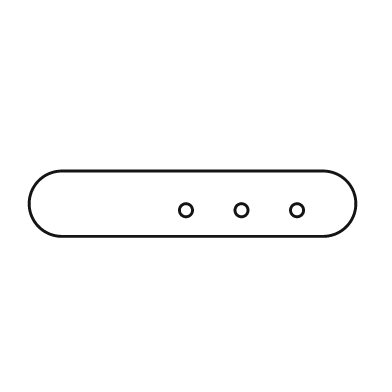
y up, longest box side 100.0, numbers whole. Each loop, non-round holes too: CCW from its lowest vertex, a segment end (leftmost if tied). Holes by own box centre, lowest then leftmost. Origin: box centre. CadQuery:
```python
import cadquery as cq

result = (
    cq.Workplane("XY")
    .moveTo(-40.0, -10.0)
    .lineTo(40.0, -10.0)
    .threePointArc((50.0, 0.0), (40.0, 10.0))
    .lineTo(-40.0, 10.0)
    .threePointArc((-50.0, 0.0), (-40.0, -10.0))
    .close()
    .moveTo(-2.0, -2.0)
    .circle(2.0)
    .moveTo(15.0, -2.0)
    .circle(2.0)
    .moveTo(32.0, -2.0)
    .circle(2.0)
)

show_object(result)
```